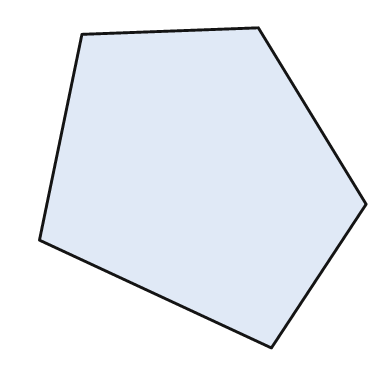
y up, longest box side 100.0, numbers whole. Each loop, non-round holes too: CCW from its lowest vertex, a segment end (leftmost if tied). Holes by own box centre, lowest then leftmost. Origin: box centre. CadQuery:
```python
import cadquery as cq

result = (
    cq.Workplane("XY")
    .moveTo(21.0, -49.0)
    .lineTo(50.0, -5.0)
    .lineTo(17.0, 49.0)
    .lineTo(-37.0, 47.0)
    .lineTo(-50.0, -16.0)
    .close()
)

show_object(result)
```